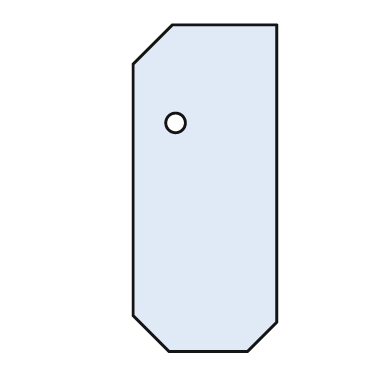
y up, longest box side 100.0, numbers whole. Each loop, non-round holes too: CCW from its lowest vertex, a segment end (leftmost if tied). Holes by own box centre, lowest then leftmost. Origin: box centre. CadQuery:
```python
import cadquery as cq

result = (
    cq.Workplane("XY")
    .moveTo(-11.0, -50.0)
    .lineTo(13.0, -50.0)
    .lineTo(22.0, -41.0)
    .lineTo(22.0, 50.0)
    .lineTo(-10.0, 50.0)
    .lineTo(-22.0, 38.0)
    .lineTo(-22.0, -39.0)
    .close()
    .moveTo(-9.0, 20.0)
    .circle(3.0)
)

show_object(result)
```